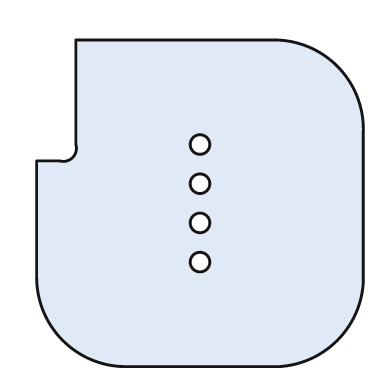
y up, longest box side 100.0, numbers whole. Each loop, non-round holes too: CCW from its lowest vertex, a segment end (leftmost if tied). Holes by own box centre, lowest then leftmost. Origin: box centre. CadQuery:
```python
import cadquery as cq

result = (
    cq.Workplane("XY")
    .moveTo(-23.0, -50.0)
    .lineTo(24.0, -50.0)
    .threePointArc((42.0, -42.0), (50.0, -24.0))
    .lineTo(50.0, 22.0)
    .threePointArc((42.0, 42.0), (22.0, 50.0))
    .lineTo(-38.0, 50.0)
    .lineTo(-38.0, 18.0)
    .threePointArc((-39.0, 14.0), (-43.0, 13.0))
    .lineTo(-50.0, 13.0)
    .lineTo(-50.0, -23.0)
    .threePointArc((-42.0, -42.0), (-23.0, -50.0))
    .close()
    .moveTo(0.0, -18.0)
    .circle(3.0)
    .moveTo(0.0, -6.0)
    .circle(3.0)
    .moveTo(0.0, 6.0)
    .circle(3.0)
    .moveTo(0.0, 18.0)
    .circle(3.0)
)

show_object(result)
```